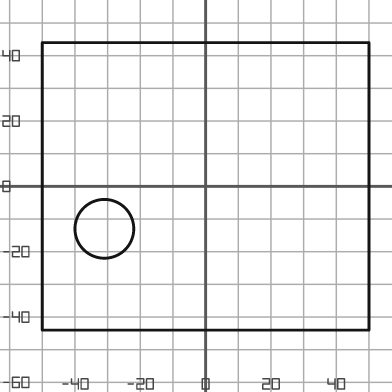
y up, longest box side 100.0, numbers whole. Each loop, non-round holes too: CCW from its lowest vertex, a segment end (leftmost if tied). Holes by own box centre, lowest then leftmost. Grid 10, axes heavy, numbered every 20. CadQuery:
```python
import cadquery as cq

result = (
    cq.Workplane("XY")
    .moveTo(-50.0, -44.0)
    .lineTo(50.0, -44.0)
    .lineTo(50.0, 44.0)
    .lineTo(-50.0, 44.0)
    .close()
    .moveTo(-31.0, -13.0)
    .circle(9.0)
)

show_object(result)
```